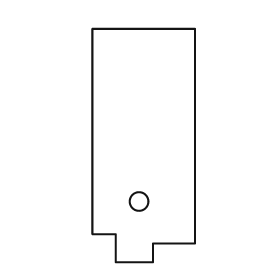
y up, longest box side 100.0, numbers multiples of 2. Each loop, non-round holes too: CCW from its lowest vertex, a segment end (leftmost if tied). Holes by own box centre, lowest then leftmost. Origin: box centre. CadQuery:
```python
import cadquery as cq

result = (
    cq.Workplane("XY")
    .moveTo(-12.0, -50.0)
    .lineTo(4.0, -50.0)
    .lineTo(4.0, -42.0)
    .lineTo(22.0, -42.0)
    .lineTo(22.0, 50.0)
    .lineTo(-22.0, 50.0)
    .lineTo(-22.0, -38.0)
    .lineTo(-12.0, -38.0)
    .close()
    .moveTo(-2.0, -24.0)
    .circle(4.0)
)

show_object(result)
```